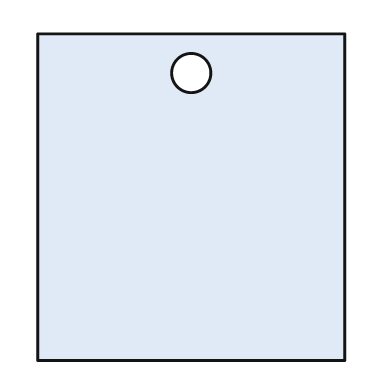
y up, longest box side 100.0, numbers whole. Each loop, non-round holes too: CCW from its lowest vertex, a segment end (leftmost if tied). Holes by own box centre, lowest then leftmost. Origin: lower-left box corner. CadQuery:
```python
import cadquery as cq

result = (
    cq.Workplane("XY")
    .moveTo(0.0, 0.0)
    .lineTo(94.0, 0.0)
    .lineTo(94.0, 100.0)
    .lineTo(0.0, 100.0)
    .close()
    .moveTo(47.0, 88.0)
    .circle(6.0)
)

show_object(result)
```